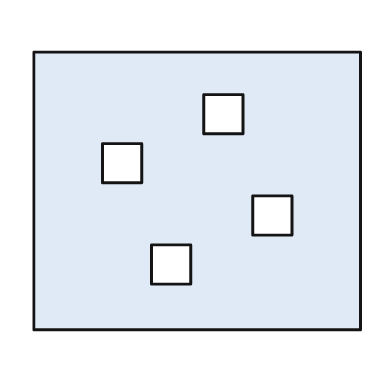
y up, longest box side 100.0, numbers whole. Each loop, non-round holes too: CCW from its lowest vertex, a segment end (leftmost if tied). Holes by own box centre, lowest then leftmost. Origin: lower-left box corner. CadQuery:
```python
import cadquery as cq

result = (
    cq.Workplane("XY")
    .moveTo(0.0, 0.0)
    .lineTo(100.0, 0.0)
    .lineTo(100.0, 85.0)
    .lineTo(0.0, 85.0)
    .close()
    .moveTo(36.0, 14.0)
    .lineTo(48.0, 14.0)
    .lineTo(48.0, 26.0)
    .lineTo(36.0, 26.0)
    .close()
    .moveTo(67.0, 29.0)
    .lineTo(79.0, 29.0)
    .lineTo(79.0, 41.0)
    .lineTo(67.0, 41.0)
    .close()
    .moveTo(21.0, 45.0)
    .lineTo(33.0, 45.0)
    .lineTo(33.0, 57.0)
    .lineTo(21.0, 57.0)
    .close()
    .moveTo(52.0, 60.0)
    .lineTo(64.0, 60.0)
    .lineTo(64.0, 72.0)
    .lineTo(52.0, 72.0)
    .close()
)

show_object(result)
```